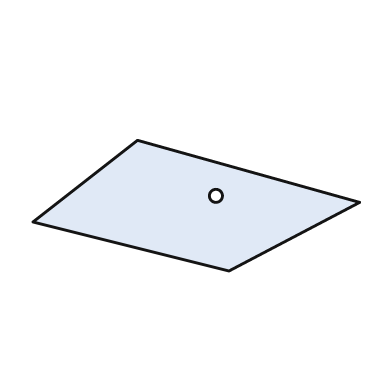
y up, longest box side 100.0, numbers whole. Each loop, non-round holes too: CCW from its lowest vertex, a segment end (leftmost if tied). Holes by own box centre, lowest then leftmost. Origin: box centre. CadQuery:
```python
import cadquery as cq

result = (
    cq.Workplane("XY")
    .moveTo(10.0, -20.0)
    .lineTo(50.0, 1.0)
    .lineTo(-18.0, 20.0)
    .lineTo(-50.0, -5.0)
    .close()
    .moveTo(6.0, 3.0)
    .circle(2.0)
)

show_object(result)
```